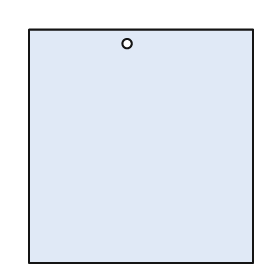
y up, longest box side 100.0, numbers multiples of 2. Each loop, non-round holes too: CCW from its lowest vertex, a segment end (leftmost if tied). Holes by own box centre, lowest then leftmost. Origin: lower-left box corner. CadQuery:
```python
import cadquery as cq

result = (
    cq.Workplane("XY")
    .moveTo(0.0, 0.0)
    .lineTo(96.0, 0.0)
    .lineTo(96.0, 100.0)
    .lineTo(0.0, 100.0)
    .close()
    .moveTo(42.0, 94.0)
    .circle(2.0)
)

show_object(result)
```